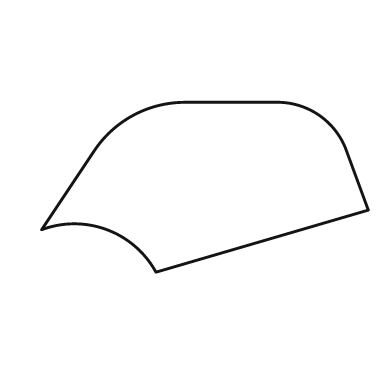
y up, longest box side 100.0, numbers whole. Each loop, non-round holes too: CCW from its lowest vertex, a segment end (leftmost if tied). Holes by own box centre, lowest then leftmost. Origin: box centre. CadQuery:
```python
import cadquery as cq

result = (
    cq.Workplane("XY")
    .moveTo(-15.0, -26.0)
    .lineTo(50.0, -7.0)
    .lineTo(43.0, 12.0)
    .threePointArc((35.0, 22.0), (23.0, 26.0))
    .lineTo(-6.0, 26.0)
    .threePointArc((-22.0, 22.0), (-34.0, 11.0))
    .lineTo(-50.0, -13.0)
    .threePointArc((-30.0, -13.0), (-15.0, -26.0))
    .close()
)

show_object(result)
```